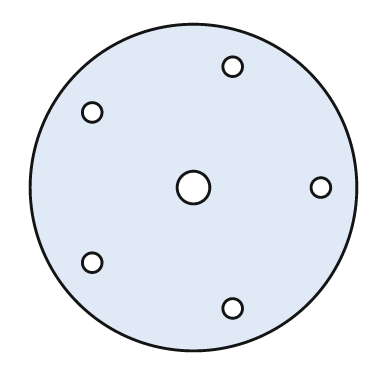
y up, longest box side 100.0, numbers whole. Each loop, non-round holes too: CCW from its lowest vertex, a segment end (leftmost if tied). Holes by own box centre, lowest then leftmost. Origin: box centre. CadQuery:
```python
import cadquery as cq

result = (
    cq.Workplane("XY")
    .moveTo(0.0, 0.0)
    .circle(50.0)
    .moveTo(12.0, -37.0)
    .circle(3.0)
    .moveTo(-31.0, -23.0)
    .circle(3.0)
    .moveTo(0.0, 0.0)
    .circle(5.0)
    .moveTo(39.0, 0.0)
    .circle(3.0)
    .moveTo(-31.0, 23.0)
    .circle(3.0)
    .moveTo(12.0, 37.0)
    .circle(3.0)
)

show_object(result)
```